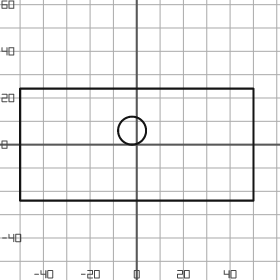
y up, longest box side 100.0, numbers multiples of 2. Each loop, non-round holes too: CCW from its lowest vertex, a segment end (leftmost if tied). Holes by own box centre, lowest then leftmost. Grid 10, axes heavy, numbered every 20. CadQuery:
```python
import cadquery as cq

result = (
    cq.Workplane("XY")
    .moveTo(-50.0, -24.0)
    .lineTo(50.0, -24.0)
    .lineTo(50.0, 24.0)
    .lineTo(-50.0, 24.0)
    .close()
    .moveTo(-2.0, 6.0)
    .circle(6.0)
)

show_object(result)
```